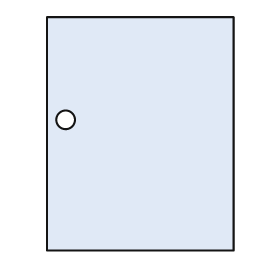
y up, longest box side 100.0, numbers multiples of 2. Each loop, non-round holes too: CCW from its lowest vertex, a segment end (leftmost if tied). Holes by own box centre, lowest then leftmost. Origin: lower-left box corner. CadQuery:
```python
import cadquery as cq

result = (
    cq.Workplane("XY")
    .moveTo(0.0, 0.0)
    .lineTo(80.0, 0.0)
    .lineTo(80.0, 100.0)
    .lineTo(0.0, 100.0)
    .close()
    .moveTo(8.0, 56.0)
    .circle(4.0)
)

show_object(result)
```